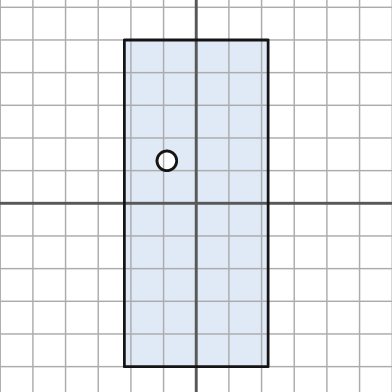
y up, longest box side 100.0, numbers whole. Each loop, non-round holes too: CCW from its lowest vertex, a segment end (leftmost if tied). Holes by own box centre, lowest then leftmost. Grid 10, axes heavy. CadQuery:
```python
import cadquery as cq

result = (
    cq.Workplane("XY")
    .moveTo(-22.0, -50.0)
    .lineTo(22.0, -50.0)
    .lineTo(22.0, 50.0)
    .lineTo(-22.0, 50.0)
    .close()
    .moveTo(-9.0, 13.0)
    .circle(3.0)
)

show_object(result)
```